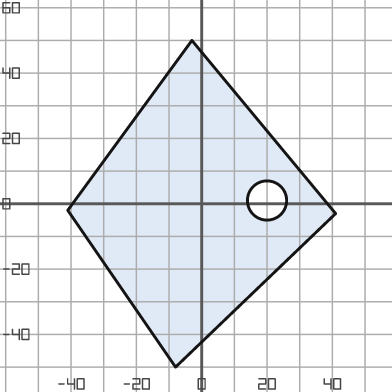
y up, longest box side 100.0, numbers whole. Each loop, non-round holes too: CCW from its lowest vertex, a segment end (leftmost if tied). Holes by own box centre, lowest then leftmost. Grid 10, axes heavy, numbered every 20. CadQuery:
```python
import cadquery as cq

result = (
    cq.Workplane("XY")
    .moveTo(-8.0, -50.0)
    .lineTo(41.0, -3.0)
    .lineTo(-3.0, 50.0)
    .lineTo(-41.0, -2.0)
    .close()
    .moveTo(20.0, 1.0)
    .circle(6.0)
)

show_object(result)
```